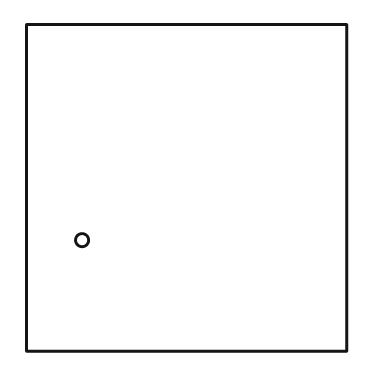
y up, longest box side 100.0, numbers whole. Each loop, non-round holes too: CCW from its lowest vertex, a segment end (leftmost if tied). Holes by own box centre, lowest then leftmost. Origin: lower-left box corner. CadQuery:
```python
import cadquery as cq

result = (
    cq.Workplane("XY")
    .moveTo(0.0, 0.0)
    .lineTo(98.0, 0.0)
    .lineTo(98.0, 100.0)
    .lineTo(0.0, 100.0)
    .close()
    .moveTo(17.0, 34.0)
    .circle(2.0)
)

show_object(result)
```